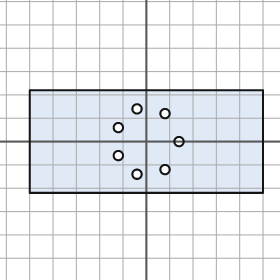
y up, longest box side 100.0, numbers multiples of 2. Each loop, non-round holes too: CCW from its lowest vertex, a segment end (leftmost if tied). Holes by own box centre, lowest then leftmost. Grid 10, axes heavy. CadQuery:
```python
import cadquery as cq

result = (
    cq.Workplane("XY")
    .moveTo(-50.0, -22.0)
    .lineTo(50.0, -22.0)
    .lineTo(50.0, 22.0)
    .lineTo(-50.0, 22.0)
    .close()
    .moveTo(-4.0, -14.0)
    .circle(2.0)
    .moveTo(8.0, -12.0)
    .circle(2.0)
    .moveTo(-12.0, -6.0)
    .circle(2.0)
    .moveTo(14.0, 0.0)
    .circle(2.0)
    .moveTo(-12.0, 6.0)
    .circle(2.0)
    .moveTo(8.0, 12.0)
    .circle(2.0)
    .moveTo(-4.0, 14.0)
    .circle(2.0)
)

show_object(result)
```